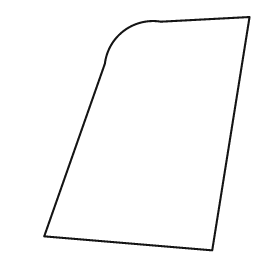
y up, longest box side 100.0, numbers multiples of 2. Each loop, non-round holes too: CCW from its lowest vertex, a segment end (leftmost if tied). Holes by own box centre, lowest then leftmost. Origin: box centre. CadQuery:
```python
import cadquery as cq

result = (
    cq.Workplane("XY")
    .moveTo(28.0, -50.0)
    .lineTo(44.0, 50.0)
    .lineTo(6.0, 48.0)
    .threePointArc((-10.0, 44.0), (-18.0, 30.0))
    .lineTo(-44.0, -44.0)
    .close()
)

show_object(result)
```